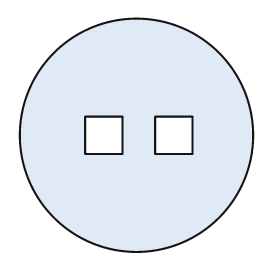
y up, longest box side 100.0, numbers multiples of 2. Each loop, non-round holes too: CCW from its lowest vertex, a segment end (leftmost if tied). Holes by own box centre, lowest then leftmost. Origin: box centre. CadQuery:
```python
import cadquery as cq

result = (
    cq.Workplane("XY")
    .moveTo(0.0, 0.0)
    .circle(50.0)
    .moveTo(-22.0, -8.0)
    .lineTo(-6.0, -8.0)
    .lineTo(-6.0, 8.0)
    .lineTo(-22.0, 8.0)
    .close()
    .moveTo(8.0, -8.0)
    .lineTo(24.0, -8.0)
    .lineTo(24.0, 8.0)
    .lineTo(8.0, 8.0)
    .close()
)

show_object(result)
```